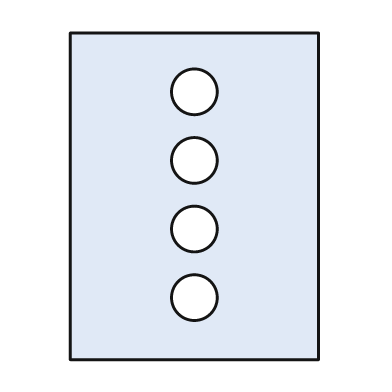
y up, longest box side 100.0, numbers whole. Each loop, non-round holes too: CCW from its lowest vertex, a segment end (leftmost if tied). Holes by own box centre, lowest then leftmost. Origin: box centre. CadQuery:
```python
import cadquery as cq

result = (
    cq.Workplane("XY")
    .moveTo(-38.0, -50.0)
    .lineTo(38.0, -50.0)
    .lineTo(38.0, 50.0)
    .lineTo(-38.0, 50.0)
    .close()
    .moveTo(0.0, -31.0)
    .circle(7.0)
    .moveTo(0.0, -10.0)
    .circle(7.0)
    .moveTo(0.0, 11.0)
    .circle(7.0)
    .moveTo(0.0, 32.0)
    .circle(7.0)
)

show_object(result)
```